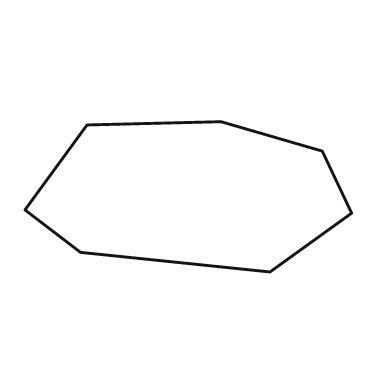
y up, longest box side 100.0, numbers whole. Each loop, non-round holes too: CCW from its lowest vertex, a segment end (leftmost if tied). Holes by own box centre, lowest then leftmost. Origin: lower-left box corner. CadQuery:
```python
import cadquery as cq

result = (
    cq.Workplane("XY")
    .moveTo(75.0, 0.0)
    .lineTo(100.0, 18.0)
    .lineTo(91.0, 37.0)
    .lineTo(60.0, 46.0)
    .lineTo(19.0, 45.0)
    .lineTo(0.0, 19.0)
    .lineTo(17.0, 6.0)
    .close()
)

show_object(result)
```